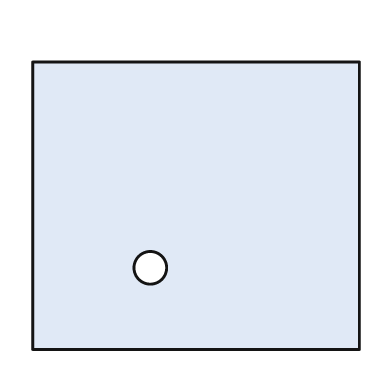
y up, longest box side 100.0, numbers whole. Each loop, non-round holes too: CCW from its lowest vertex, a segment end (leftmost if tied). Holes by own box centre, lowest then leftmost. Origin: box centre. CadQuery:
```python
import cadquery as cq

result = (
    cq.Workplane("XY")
    .moveTo(-50.0, -44.0)
    .lineTo(50.0, -44.0)
    .lineTo(50.0, 44.0)
    .lineTo(-50.0, 44.0)
    .close()
    .moveTo(-14.0, -19.0)
    .circle(5.0)
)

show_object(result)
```